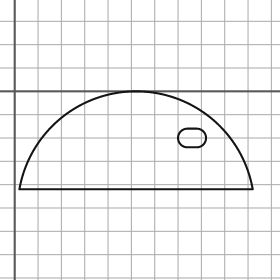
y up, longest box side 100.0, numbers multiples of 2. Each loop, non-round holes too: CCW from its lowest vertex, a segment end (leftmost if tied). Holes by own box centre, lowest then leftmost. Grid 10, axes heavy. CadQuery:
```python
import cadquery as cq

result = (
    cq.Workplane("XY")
    .moveTo(2.0, -42.0)
    .lineTo(102.0, -42.0)
    .threePointArc((52.0, 0.0), (2.0, -42.0))
    .close()
    .moveTo(74.0, -24.0)
    .lineTo(78.0, -24.0)
    .threePointArc((82.0, -20.0), (78.0, -16.0))
    .lineTo(74.0, -16.0)
    .threePointArc((70.0, -20.0), (74.0, -24.0))
    .close()
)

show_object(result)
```